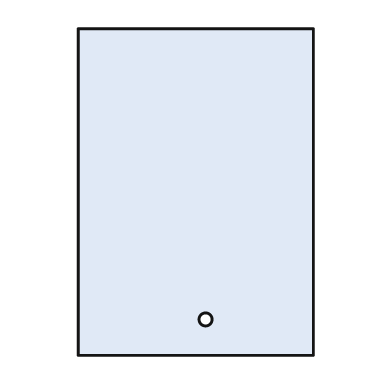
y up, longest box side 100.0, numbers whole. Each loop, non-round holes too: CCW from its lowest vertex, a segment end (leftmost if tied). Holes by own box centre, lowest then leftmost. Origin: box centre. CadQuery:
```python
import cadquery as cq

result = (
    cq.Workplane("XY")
    .moveTo(-36.0, -50.0)
    .lineTo(36.0, -50.0)
    .lineTo(36.0, 50.0)
    .lineTo(-36.0, 50.0)
    .close()
    .moveTo(3.0, -39.0)
    .circle(2.0)
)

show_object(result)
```